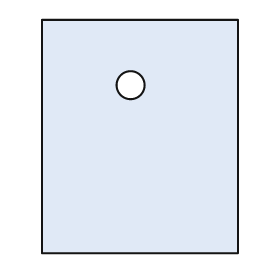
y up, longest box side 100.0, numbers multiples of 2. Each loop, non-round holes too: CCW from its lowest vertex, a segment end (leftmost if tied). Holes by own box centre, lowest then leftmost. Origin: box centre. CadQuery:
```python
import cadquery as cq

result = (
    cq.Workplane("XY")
    .moveTo(-42.0, -50.0)
    .lineTo(42.0, -50.0)
    .lineTo(42.0, 50.0)
    .lineTo(-42.0, 50.0)
    .close()
    .moveTo(-4.0, 22.0)
    .circle(6.0)
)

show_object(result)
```